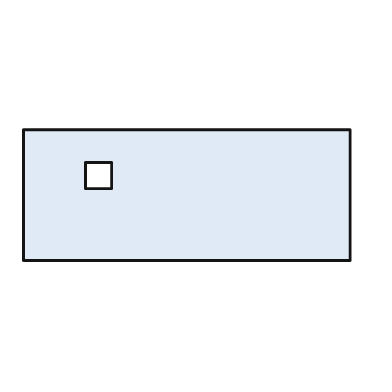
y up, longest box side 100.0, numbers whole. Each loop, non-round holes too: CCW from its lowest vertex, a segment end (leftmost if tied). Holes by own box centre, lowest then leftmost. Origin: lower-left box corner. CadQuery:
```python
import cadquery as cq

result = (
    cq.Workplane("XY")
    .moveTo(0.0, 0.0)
    .lineTo(100.0, 0.0)
    .lineTo(100.0, 40.0)
    .lineTo(0.0, 40.0)
    .close()
    .moveTo(19.0, 22.0)
    .lineTo(27.0, 22.0)
    .lineTo(27.0, 30.0)
    .lineTo(19.0, 30.0)
    .close()
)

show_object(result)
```